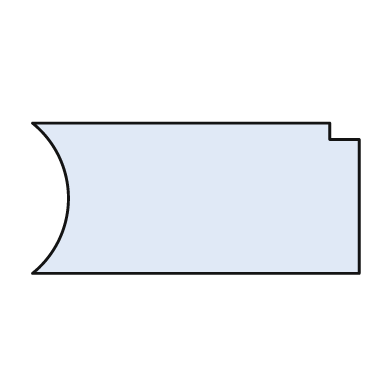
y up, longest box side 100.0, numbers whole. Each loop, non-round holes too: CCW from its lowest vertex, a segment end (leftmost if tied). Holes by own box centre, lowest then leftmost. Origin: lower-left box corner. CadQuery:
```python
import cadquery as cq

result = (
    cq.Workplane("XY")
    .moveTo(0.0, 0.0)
    .lineTo(100.0, 0.0)
    .lineTo(100.0, 41.0)
    .lineTo(91.0, 41.0)
    .lineTo(91.0, 46.0)
    .lineTo(0.0, 46.0)
    .threePointArc((11.0, 23.0), (0.0, 0.0))
    .close()
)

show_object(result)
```